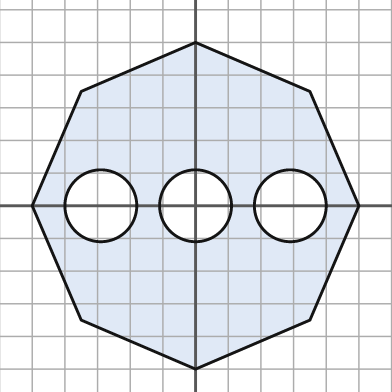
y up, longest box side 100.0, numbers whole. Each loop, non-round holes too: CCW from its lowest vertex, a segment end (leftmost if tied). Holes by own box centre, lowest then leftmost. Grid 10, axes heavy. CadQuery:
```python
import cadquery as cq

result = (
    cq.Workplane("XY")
    .moveTo(0.0, -50.0)
    .lineTo(35.0, -35.0)
    .lineTo(50.0, 0.0)
    .lineTo(35.0, 35.0)
    .lineTo(0.0, 50.0)
    .lineTo(-35.0, 35.0)
    .lineTo(-50.0, 0.0)
    .lineTo(-35.0, -35.0)
    .close()
    .moveTo(-29.0, 0.0)
    .circle(11.0)
    .moveTo(0.0, 0.0)
    .circle(11.0)
    .moveTo(29.0, 0.0)
    .circle(11.0)
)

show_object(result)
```